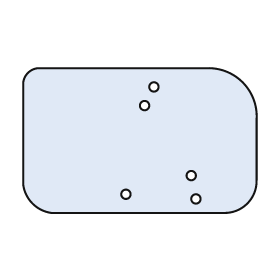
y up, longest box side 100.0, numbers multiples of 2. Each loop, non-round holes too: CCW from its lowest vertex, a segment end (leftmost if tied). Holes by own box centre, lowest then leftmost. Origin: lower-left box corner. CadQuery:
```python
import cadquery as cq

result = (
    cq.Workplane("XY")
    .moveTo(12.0, 0.0)
    .lineTo(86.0, 0.0)
    .threePointArc((96.0, 4.0), (100.0, 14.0))
    .lineTo(100.0, 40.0)
    .threePointArc((94.0, 56.0), (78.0, 62.0))
    .lineTo(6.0, 62.0)
    .threePointArc((2.0, 60.0), (0.0, 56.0))
    .lineTo(0.0, 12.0)
    .threePointArc((4.0, 4.0), (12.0, 0.0))
    .close()
    .moveTo(74.0, 6.0)
    .circle(2.0)
    .moveTo(44.0, 8.0)
    .circle(2.0)
    .moveTo(72.0, 16.0)
    .circle(2.0)
    .moveTo(52.0, 46.0)
    .circle(2.0)
    .moveTo(56.0, 54.0)
    .circle(2.0)
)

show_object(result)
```